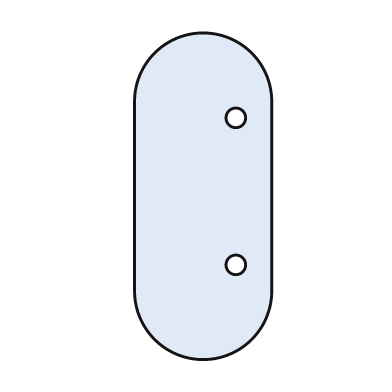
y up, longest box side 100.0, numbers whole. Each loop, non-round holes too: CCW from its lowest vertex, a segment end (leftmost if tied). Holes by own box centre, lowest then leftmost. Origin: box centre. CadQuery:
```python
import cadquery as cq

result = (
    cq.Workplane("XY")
    .moveTo(-21.0, -29.0)
    .threePointArc((0.0, -50.0), (21.0, -29.0))
    .lineTo(21.0, 29.0)
    .threePointArc((0.0, 50.0), (-21.0, 29.0))
    .close()
    .moveTo(10.0, -21.0)
    .circle(3.0)
    .moveTo(10.0, 24.0)
    .circle(3.0)
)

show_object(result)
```